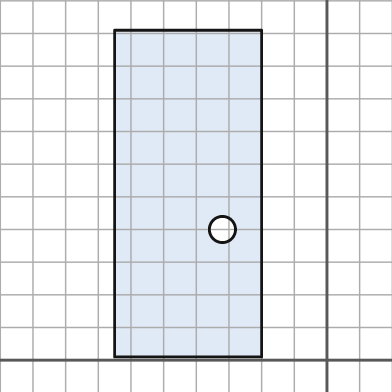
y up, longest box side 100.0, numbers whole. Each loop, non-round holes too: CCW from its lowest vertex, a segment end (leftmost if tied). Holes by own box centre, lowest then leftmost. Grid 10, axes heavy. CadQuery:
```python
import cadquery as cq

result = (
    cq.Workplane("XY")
    .moveTo(-65.0, 1.0)
    .lineTo(-20.0, 1.0)
    .lineTo(-20.0, 101.0)
    .lineTo(-65.0, 101.0)
    .close()
    .moveTo(-32.0, 40.0)
    .circle(4.0)
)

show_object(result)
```